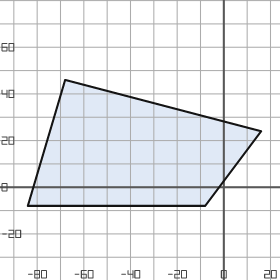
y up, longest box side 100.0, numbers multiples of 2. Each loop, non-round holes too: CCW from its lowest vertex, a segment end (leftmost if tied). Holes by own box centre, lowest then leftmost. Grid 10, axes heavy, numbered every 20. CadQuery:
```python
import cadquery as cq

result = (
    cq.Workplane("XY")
    .moveTo(-84.0, -8.0)
    .lineTo(-8.0, -8.0)
    .lineTo(16.0, 24.0)
    .lineTo(-68.0, 46.0)
    .close()
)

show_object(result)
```